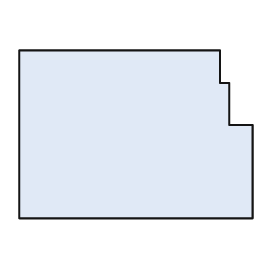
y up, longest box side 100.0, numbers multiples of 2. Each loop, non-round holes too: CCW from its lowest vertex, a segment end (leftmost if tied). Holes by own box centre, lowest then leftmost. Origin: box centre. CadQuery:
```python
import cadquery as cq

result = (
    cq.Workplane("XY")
    .moveTo(-50.0, -36.0)
    .lineTo(50.0, -36.0)
    .lineTo(50.0, 4.0)
    .lineTo(40.0, 4.0)
    .lineTo(40.0, 22.0)
    .lineTo(36.0, 22.0)
    .lineTo(36.0, 36.0)
    .lineTo(-50.0, 36.0)
    .close()
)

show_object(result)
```